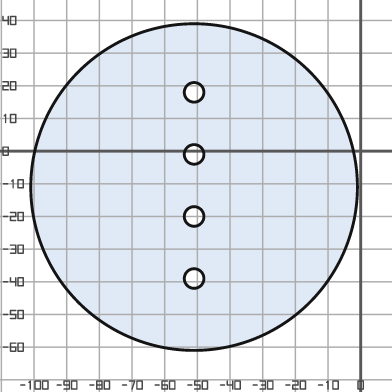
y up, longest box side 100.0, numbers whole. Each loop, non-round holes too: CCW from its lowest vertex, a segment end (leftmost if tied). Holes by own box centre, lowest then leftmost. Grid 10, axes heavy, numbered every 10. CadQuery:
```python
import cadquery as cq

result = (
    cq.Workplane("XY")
    .moveTo(-51.0, -11.0)
    .circle(50.0)
    .moveTo(-51.0, -39.0)
    .circle(3.0)
    .moveTo(-51.0, -20.0)
    .circle(3.0)
    .moveTo(-51.0, -1.0)
    .circle(3.0)
    .moveTo(-51.0, 18.0)
    .circle(3.0)
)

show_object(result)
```